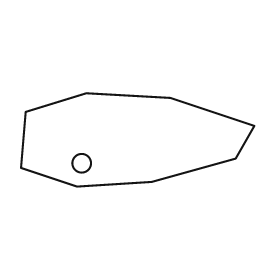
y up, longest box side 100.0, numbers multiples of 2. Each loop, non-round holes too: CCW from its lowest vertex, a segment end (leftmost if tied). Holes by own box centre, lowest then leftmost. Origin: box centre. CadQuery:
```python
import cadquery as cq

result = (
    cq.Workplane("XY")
    .moveTo(-26.0, -20.0)
    .lineTo(6.0, -18.0)
    .lineTo(42.0, -8.0)
    .lineTo(50.0, 6.0)
    .lineTo(14.0, 18.0)
    .lineTo(-22.0, 20.0)
    .lineTo(-48.0, 12.0)
    .lineTo(-50.0, -12.0)
    .close()
    .moveTo(-24.0, -10.0)
    .circle(4.0)
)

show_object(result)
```